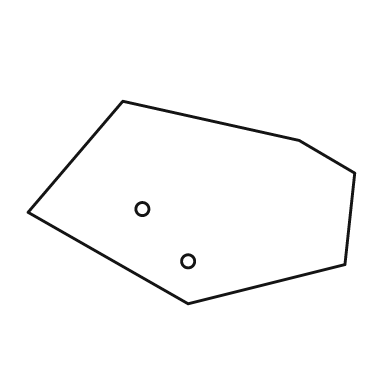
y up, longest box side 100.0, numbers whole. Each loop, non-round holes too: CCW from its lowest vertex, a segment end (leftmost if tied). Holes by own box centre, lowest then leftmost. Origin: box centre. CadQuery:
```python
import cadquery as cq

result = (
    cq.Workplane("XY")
    .moveTo(-1.0, -31.0)
    .lineTo(47.0, -19.0)
    .lineTo(50.0, 9.0)
    .lineTo(33.0, 19.0)
    .lineTo(-21.0, 31.0)
    .lineTo(-50.0, -3.0)
    .close()
    .moveTo(-1.0, -18.0)
    .circle(2.0)
    .moveTo(-15.0, -2.0)
    .circle(2.0)
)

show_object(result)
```